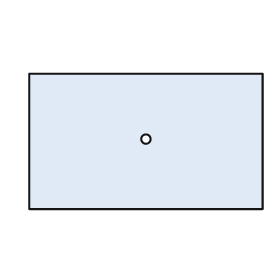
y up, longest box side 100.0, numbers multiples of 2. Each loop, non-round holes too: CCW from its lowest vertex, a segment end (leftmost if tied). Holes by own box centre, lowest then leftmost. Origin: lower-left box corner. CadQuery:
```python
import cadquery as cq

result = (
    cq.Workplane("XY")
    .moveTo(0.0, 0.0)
    .lineTo(100.0, 0.0)
    .lineTo(100.0, 58.0)
    .lineTo(0.0, 58.0)
    .close()
    .moveTo(50.0, 30.0)
    .circle(2.0)
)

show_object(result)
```